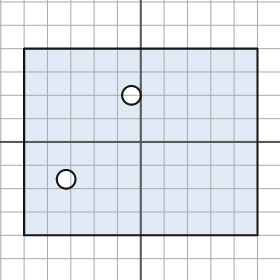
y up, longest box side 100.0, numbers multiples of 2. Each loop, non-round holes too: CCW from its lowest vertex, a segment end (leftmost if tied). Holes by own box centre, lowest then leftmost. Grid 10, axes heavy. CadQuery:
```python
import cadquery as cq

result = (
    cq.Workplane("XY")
    .moveTo(-50.0, -40.0)
    .lineTo(50.0, -40.0)
    .lineTo(50.0, 40.0)
    .lineTo(-50.0, 40.0)
    .close()
    .moveTo(-32.0, -16.0)
    .circle(4.0)
    .moveTo(-4.0, 20.0)
    .circle(4.0)
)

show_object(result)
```